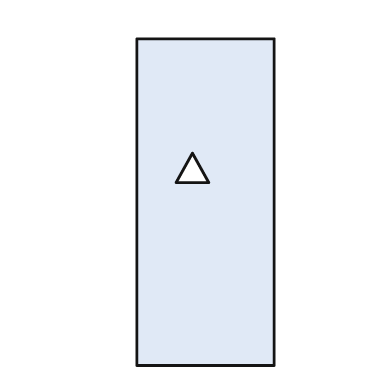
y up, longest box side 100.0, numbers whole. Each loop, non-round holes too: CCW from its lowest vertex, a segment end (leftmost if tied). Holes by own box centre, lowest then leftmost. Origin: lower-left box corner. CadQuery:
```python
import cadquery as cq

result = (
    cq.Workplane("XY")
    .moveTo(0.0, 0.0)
    .lineTo(42.0, 0.0)
    .lineTo(42.0, 100.0)
    .lineTo(0.0, 100.0)
    .close()
    .moveTo(12.0, 56.0)
    .lineTo(22.0, 56.0)
    .lineTo(17.0, 65.0)
    .close()
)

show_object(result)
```